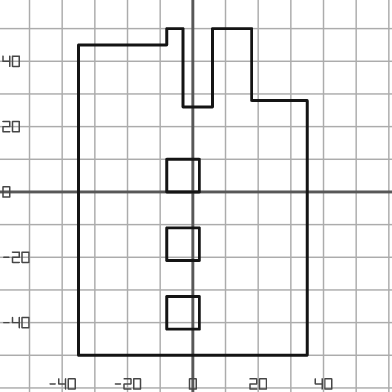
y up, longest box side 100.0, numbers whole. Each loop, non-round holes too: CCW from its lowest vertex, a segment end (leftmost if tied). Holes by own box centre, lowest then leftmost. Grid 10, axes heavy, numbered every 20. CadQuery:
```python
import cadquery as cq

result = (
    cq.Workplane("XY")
    .moveTo(-35.0, -50.0)
    .lineTo(35.0, -50.0)
    .lineTo(35.0, 28.0)
    .lineTo(18.0, 28.0)
    .lineTo(18.0, 50.0)
    .lineTo(6.0, 50.0)
    .lineTo(6.0, 26.0)
    .lineTo(-3.0, 26.0)
    .lineTo(-3.0, 50.0)
    .lineTo(-8.0, 50.0)
    .lineTo(-8.0, 45.0)
    .lineTo(-35.0, 45.0)
    .close()
    .moveTo(-8.0, -42.0)
    .lineTo(2.0, -42.0)
    .lineTo(2.0, -32.0)
    .lineTo(-8.0, -32.0)
    .close()
    .moveTo(-8.0, -21.0)
    .lineTo(2.0, -21.0)
    .lineTo(2.0, -11.0)
    .lineTo(-8.0, -11.0)
    .close()
    .moveTo(-8.0, 0.0)
    .lineTo(2.0, 0.0)
    .lineTo(2.0, 10.0)
    .lineTo(-8.0, 10.0)
    .close()
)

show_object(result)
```